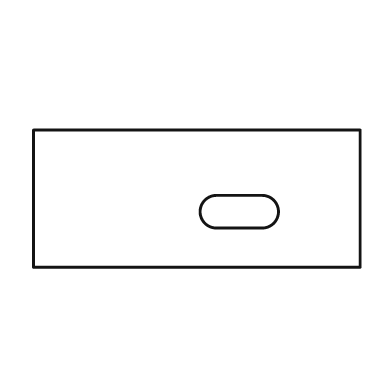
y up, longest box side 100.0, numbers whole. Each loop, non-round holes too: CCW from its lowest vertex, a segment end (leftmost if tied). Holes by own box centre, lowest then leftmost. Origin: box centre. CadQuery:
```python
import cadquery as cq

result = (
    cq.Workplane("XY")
    .moveTo(-50.0, -21.0)
    .lineTo(50.0, -21.0)
    .lineTo(50.0, 21.0)
    .lineTo(-50.0, 21.0)
    .close()
    .moveTo(6.0, -9.0)
    .lineTo(20.0, -9.0)
    .threePointArc((25.0, -4.0), (20.0, 1.0))
    .lineTo(6.0, 1.0)
    .threePointArc((1.0, -4.0), (6.0, -9.0))
    .close()
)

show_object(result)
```